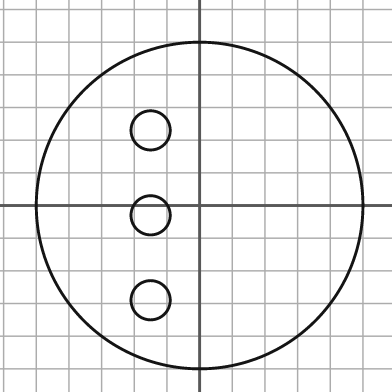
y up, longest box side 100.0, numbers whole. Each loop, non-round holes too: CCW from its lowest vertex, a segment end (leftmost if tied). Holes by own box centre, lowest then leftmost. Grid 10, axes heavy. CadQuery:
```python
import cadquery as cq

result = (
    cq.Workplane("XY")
    .moveTo(0.0, 0.0)
    .circle(50.0)
    .moveTo(-15.0, -29.0)
    .circle(6.0)
    .moveTo(-15.0, -3.0)
    .circle(6.0)
    .moveTo(-15.0, 23.0)
    .circle(6.0)
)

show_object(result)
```